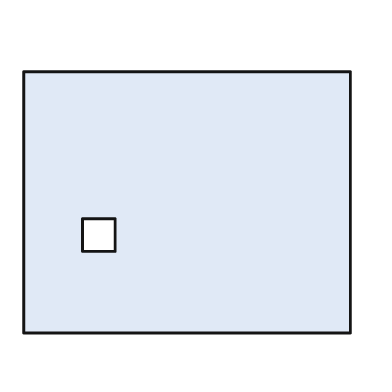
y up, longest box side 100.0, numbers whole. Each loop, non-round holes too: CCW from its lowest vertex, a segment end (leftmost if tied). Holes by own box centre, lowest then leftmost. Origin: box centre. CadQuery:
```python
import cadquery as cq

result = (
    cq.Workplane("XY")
    .moveTo(-50.0, -40.0)
    .lineTo(50.0, -40.0)
    .lineTo(50.0, 40.0)
    .lineTo(-50.0, 40.0)
    .close()
    .moveTo(-32.0, -15.0)
    .lineTo(-22.0, -15.0)
    .lineTo(-22.0, -5.0)
    .lineTo(-32.0, -5.0)
    .close()
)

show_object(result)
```